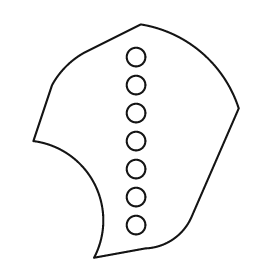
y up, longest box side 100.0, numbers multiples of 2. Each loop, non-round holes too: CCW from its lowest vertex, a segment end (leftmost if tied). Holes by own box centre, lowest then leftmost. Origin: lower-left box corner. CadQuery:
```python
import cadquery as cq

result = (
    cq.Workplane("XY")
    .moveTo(26.0, 0.0)
    .lineTo(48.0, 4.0)
    .threePointArc((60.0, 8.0), (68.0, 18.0))
    .lineTo(88.0, 64.0)
    .threePointArc((72.0, 88.0), (46.0, 100.0))
    .lineTo(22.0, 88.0)
    .threePointArc((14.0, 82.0), (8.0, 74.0))
    .lineTo(0.0, 50.0)
    .threePointArc((26.0, 32.0), (26.0, 0.0))
    .close()
    .moveTo(44.0, 14.0)
    .circle(4.0)
    .moveTo(44.0, 26.0)
    .circle(4.0)
    .moveTo(44.0, 38.0)
    .circle(4.0)
    .moveTo(44.0, 50.0)
    .circle(4.0)
    .moveTo(44.0, 62.0)
    .circle(4.0)
    .moveTo(44.0, 74.0)
    .circle(4.0)
    .moveTo(44.0, 86.0)
    .circle(4.0)
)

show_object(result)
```